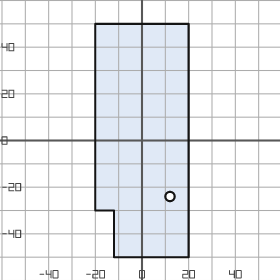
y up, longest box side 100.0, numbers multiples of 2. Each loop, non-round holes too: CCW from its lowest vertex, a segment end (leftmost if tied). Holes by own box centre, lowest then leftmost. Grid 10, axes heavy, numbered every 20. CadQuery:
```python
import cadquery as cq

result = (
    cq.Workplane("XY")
    .moveTo(-12.0, -50.0)
    .lineTo(20.0, -50.0)
    .lineTo(20.0, 50.0)
    .lineTo(-20.0, 50.0)
    .lineTo(-20.0, -30.0)
    .lineTo(-12.0, -30.0)
    .close()
    .moveTo(12.0, -24.0)
    .circle(2.0)
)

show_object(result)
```